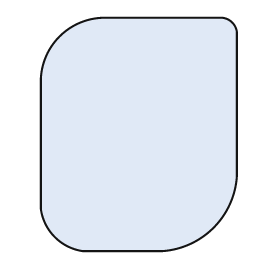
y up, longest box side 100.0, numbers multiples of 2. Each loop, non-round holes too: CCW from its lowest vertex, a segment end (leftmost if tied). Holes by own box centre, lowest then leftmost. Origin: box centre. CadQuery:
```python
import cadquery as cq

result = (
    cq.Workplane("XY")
    .moveTo(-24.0, -50.0)
    .lineTo(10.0, -50.0)
    .threePointArc((32.0, -40.0), (42.0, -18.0))
    .lineTo(42.0, 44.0)
    .threePointArc((40.0, 48.0), (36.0, 50.0))
    .lineTo(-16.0, 50.0)
    .threePointArc((-34.0, 42.0), (-42.0, 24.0))
    .lineTo(-42.0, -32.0)
    .threePointArc((-36.0, -44.0), (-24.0, -50.0))
    .close()
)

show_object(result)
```